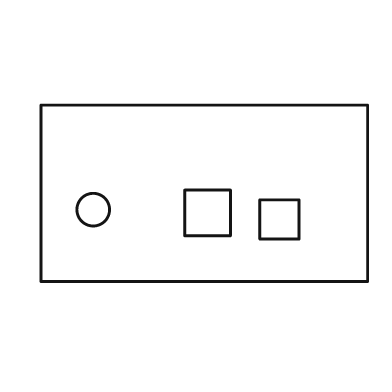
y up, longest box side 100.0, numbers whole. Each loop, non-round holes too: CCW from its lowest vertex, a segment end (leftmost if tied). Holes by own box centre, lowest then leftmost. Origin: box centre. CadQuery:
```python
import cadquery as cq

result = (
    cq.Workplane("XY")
    .moveTo(-50.0, -27.0)
    .lineTo(50.0, -27.0)
    .lineTo(50.0, 27.0)
    .lineTo(-50.0, 27.0)
    .close()
    .moveTo(17.0, -14.0)
    .lineTo(29.0, -14.0)
    .lineTo(29.0, -2.0)
    .lineTo(17.0, -2.0)
    .close()
    .moveTo(-6.0, -13.0)
    .lineTo(8.0, -13.0)
    .lineTo(8.0, 1.0)
    .lineTo(-6.0, 1.0)
    .close()
    .moveTo(-34.0, -5.0)
    .circle(5.0)
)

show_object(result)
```